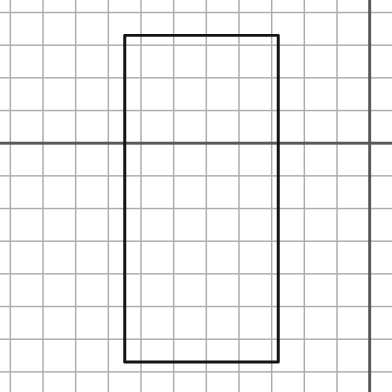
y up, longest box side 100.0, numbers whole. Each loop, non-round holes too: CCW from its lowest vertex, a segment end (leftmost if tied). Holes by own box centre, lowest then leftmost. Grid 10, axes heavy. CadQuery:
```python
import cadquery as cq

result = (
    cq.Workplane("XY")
    .moveTo(-75.0, -67.0)
    .lineTo(-28.0, -67.0)
    .lineTo(-28.0, 33.0)
    .lineTo(-75.0, 33.0)
    .close()
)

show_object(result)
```